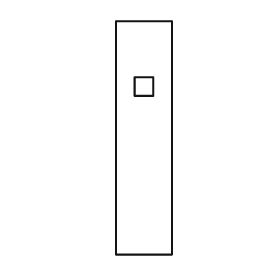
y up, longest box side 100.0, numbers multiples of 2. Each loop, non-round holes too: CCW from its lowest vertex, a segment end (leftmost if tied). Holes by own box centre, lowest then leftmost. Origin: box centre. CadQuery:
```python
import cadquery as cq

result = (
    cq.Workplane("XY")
    .moveTo(-12.0, -50.0)
    .lineTo(12.0, -50.0)
    .lineTo(12.0, 50.0)
    .lineTo(-12.0, 50.0)
    .close()
    .moveTo(-4.0, 18.0)
    .lineTo(4.0, 18.0)
    .lineTo(4.0, 26.0)
    .lineTo(-4.0, 26.0)
    .close()
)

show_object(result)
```